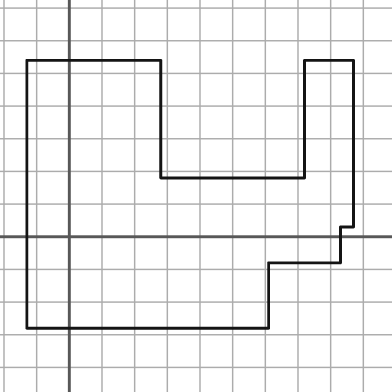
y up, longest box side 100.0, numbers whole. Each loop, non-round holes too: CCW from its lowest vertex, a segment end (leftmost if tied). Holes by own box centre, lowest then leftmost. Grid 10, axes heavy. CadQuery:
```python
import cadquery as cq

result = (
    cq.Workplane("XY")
    .moveTo(-13.0, -28.0)
    .lineTo(61.0, -28.0)
    .lineTo(61.0, -8.0)
    .lineTo(83.0, -8.0)
    .lineTo(83.0, 3.0)
    .lineTo(87.0, 3.0)
    .lineTo(87.0, 54.0)
    .lineTo(72.0, 54.0)
    .lineTo(72.0, 18.0)
    .lineTo(28.0, 18.0)
    .lineTo(28.0, 54.0)
    .lineTo(-13.0, 54.0)
    .close()
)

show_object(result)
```